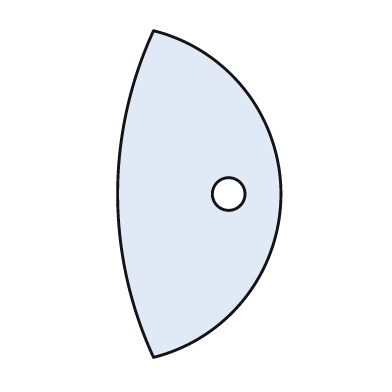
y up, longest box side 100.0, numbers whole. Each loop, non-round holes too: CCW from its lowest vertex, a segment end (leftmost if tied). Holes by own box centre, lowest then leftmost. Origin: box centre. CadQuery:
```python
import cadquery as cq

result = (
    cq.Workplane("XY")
    .moveTo(-14.0, -50.0)
    .threePointArc((25.0, 0.0), (-14.0, 50.0))
    .threePointArc((-25.0, 0.0), (-14.0, -50.0))
    .close()
    .moveTo(9.0, 0.0)
    .circle(5.0)
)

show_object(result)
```